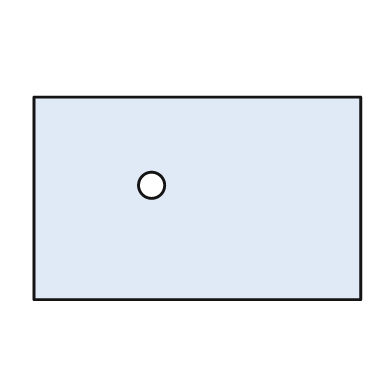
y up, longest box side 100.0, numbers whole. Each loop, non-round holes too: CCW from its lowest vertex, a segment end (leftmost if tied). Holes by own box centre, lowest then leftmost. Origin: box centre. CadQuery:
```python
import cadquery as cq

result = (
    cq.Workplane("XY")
    .moveTo(-50.0, -31.0)
    .lineTo(50.0, -31.0)
    .lineTo(50.0, 31.0)
    .lineTo(-50.0, 31.0)
    .close()
    .moveTo(-14.0, 4.0)
    .circle(4.0)
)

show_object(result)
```